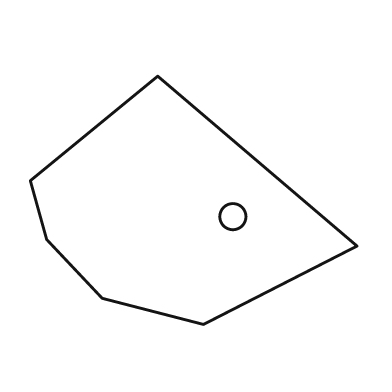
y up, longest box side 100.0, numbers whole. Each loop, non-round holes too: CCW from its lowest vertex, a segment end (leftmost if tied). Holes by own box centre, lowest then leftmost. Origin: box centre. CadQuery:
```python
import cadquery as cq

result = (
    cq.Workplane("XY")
    .moveTo(3.0, -38.0)
    .lineTo(50.0, -14.0)
    .lineTo(-11.0, 38.0)
    .lineTo(-50.0, 6.0)
    .lineTo(-45.0, -12.0)
    .lineTo(-28.0, -30.0)
    .close()
    .moveTo(12.0, -5.0)
    .circle(4.0)
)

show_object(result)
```